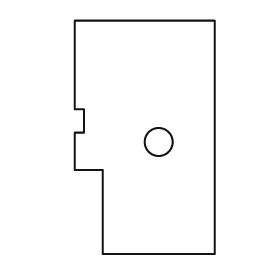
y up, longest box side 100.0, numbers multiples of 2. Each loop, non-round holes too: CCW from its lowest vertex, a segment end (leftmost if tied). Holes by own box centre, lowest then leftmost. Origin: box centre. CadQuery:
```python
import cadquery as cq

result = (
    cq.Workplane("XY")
    .moveTo(-18.0, -50.0)
    .lineTo(30.0, -50.0)
    .lineTo(30.0, 50.0)
    .lineTo(-30.0, 50.0)
    .lineTo(-30.0, 12.0)
    .lineTo(-26.0, 12.0)
    .lineTo(-26.0, 2.0)
    .lineTo(-30.0, 2.0)
    .lineTo(-30.0, -14.0)
    .lineTo(-18.0, -14.0)
    .close()
    .moveTo(6.0, -2.0)
    .circle(6.0)
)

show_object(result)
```